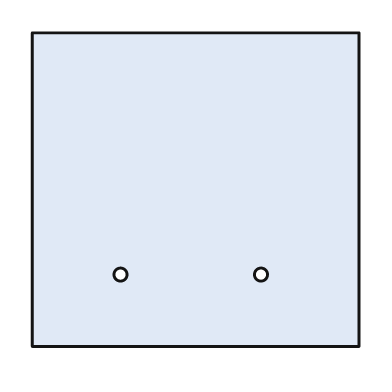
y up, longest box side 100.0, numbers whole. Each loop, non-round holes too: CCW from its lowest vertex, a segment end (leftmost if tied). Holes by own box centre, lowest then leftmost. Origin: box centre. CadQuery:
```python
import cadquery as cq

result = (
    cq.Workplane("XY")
    .moveTo(-50.0, -48.0)
    .lineTo(50.0, -48.0)
    .lineTo(50.0, 48.0)
    .lineTo(-50.0, 48.0)
    .close()
    .moveTo(-23.0, -26.0)
    .circle(2.0)
    .moveTo(20.0, -26.0)
    .circle(2.0)
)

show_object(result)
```